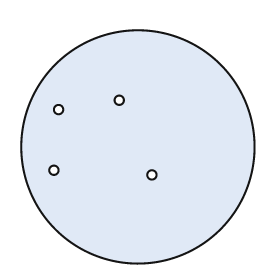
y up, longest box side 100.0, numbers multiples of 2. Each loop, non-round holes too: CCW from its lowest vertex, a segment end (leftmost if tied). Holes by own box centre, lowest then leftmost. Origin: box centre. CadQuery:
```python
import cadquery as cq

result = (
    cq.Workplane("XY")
    .moveTo(0.0, 0.0)
    .circle(50.0)
    .moveTo(6.0, -12.0)
    .circle(2.0)
    .moveTo(-36.0, -10.0)
    .circle(2.0)
    .moveTo(-34.0, 16.0)
    .circle(2.0)
    .moveTo(-8.0, 20.0)
    .circle(2.0)
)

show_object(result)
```